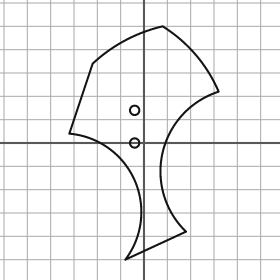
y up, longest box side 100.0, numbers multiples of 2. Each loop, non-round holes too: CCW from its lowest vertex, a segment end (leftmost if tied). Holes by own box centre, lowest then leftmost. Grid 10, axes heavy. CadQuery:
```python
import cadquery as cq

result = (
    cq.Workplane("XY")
    .moveTo(-8.0, -50.0)
    .lineTo(18.0, -38.0)
    .threePointArc((8.0, -4.0), (32.0, 22.0))
    .threePointArc((22.0, 38.0), (8.0, 50.0))
    .threePointArc((-8.0, 44.0), (-22.0, 34.0))
    .lineTo(-32.0, 4.0)
    .threePointArc((-4.0, -16.0), (-8.0, -50.0))
    .close()
    .moveTo(-4.0, 0.0)
    .circle(2.0)
    .moveTo(-4.0, 14.0)
    .circle(2.0)
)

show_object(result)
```